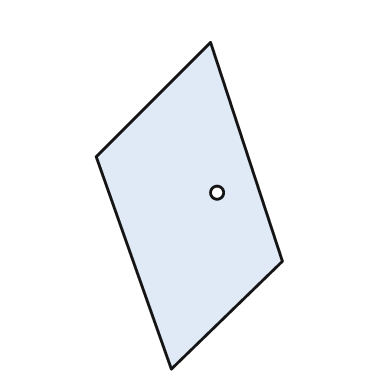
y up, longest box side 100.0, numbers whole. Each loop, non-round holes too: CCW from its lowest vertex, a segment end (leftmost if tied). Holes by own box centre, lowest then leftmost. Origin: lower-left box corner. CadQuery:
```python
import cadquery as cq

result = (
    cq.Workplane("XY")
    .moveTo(23.0, 0.0)
    .lineTo(57.0, 33.0)
    .lineTo(35.0, 100.0)
    .lineTo(0.0, 65.0)
    .close()
    .moveTo(37.0, 54.0)
    .circle(2.0)
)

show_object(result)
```